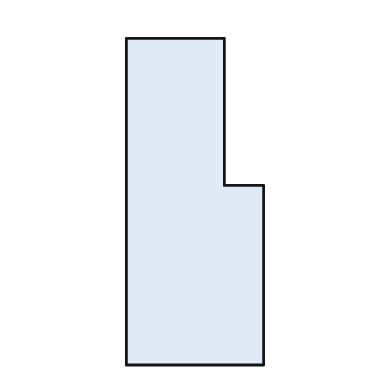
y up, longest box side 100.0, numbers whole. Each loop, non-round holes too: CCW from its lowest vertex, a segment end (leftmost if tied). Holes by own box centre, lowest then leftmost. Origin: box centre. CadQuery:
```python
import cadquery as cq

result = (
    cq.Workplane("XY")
    .moveTo(-21.0, -50.0)
    .lineTo(21.0, -50.0)
    .lineTo(21.0, 5.0)
    .lineTo(9.0, 5.0)
    .lineTo(9.0, 50.0)
    .lineTo(-21.0, 50.0)
    .close()
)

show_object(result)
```